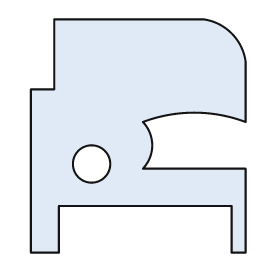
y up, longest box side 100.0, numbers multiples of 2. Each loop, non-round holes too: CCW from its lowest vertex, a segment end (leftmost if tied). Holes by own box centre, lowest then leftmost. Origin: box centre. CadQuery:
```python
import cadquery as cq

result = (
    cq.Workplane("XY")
    .moveTo(-46.0, -50.0)
    .lineTo(-34.0, -50.0)
    .lineTo(-34.0, -30.0)
    .lineTo(40.0, -30.0)
    .lineTo(40.0, -50.0)
    .lineTo(46.0, -50.0)
    .lineTo(46.0, -14.0)
    .lineTo(2.0, -14.0)
    .threePointArc((6.0, -4.0), (2.0, 6.0))
    .threePointArc((24.0, 10.0), (46.0, 6.0))
    .lineTo(46.0, 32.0)
    .threePointArc((40.0, 44.0), (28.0, 50.0))
    .lineTo(-36.0, 50.0)
    .lineTo(-36.0, 20.0)
    .lineTo(-46.0, 20.0)
    .close()
    .moveTo(-20.0, -12.0)
    .circle(8.0)
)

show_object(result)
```